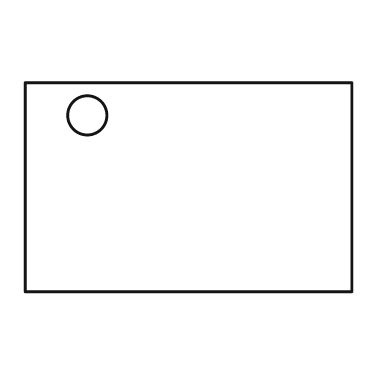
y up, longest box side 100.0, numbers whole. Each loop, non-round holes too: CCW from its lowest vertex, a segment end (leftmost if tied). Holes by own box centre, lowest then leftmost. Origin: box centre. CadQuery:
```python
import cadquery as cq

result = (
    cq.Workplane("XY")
    .moveTo(-50.0, -32.0)
    .lineTo(50.0, -32.0)
    .lineTo(50.0, 32.0)
    .lineTo(-50.0, 32.0)
    .close()
    .moveTo(-31.0, 22.0)
    .circle(6.0)
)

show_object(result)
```